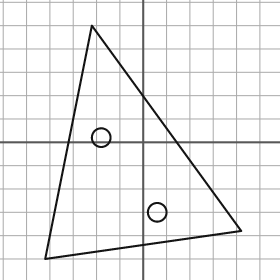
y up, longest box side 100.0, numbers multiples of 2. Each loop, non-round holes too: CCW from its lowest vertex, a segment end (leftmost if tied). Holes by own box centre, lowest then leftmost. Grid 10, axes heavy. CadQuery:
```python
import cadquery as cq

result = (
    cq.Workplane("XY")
    .moveTo(-42.0, -50.0)
    .lineTo(42.0, -38.0)
    .lineTo(-22.0, 50.0)
    .close()
    .moveTo(6.0, -30.0)
    .circle(4.0)
    .moveTo(-18.0, 2.0)
    .circle(4.0)
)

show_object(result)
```